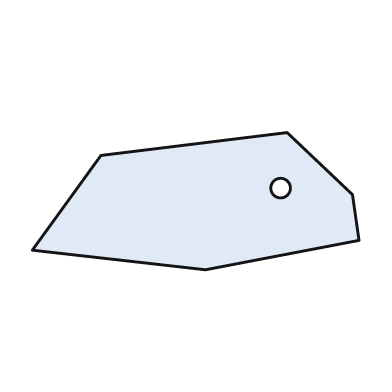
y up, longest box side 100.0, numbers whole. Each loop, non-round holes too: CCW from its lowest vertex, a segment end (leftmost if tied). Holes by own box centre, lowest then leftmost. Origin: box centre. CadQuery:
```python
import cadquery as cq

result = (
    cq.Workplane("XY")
    .moveTo(3.0, -21.0)
    .lineTo(50.0, -12.0)
    .lineTo(48.0, 2.0)
    .lineTo(28.0, 21.0)
    .lineTo(-29.0, 14.0)
    .lineTo(-50.0, -15.0)
    .close()
    .moveTo(26.0, 4.0)
    .circle(3.0)
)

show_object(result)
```